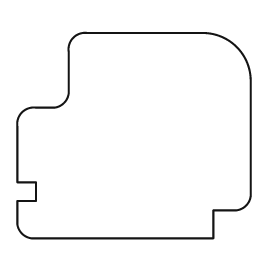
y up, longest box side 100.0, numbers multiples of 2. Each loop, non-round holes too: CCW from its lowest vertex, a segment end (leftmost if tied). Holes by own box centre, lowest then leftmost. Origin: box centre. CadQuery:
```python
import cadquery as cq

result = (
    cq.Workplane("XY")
    .moveTo(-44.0, -44.0)
    .lineTo(34.0, -44.0)
    .lineTo(34.0, -32.0)
    .lineTo(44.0, -32.0)
    .threePointArc((48.0, -30.0), (50.0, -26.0))
    .lineTo(50.0, 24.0)
    .threePointArc((44.0, 38.0), (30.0, 44.0))
    .lineTo(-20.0, 44.0)
    .threePointArc((-26.0, 42.0), (-28.0, 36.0))
    .lineTo(-28.0, 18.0)
    .threePointArc((-30.0, 14.0), (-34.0, 12.0))
    .lineTo(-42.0, 12.0)
    .threePointArc((-48.0, 10.0), (-50.0, 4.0))
    .lineTo(-50.0, -20.0)
    .lineTo(-42.0, -20.0)
    .lineTo(-42.0, -28.0)
    .lineTo(-50.0, -28.0)
    .lineTo(-50.0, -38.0)
    .threePointArc((-48.0, -42.0), (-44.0, -44.0))
    .close()
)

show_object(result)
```